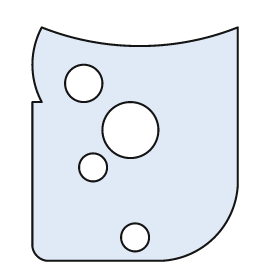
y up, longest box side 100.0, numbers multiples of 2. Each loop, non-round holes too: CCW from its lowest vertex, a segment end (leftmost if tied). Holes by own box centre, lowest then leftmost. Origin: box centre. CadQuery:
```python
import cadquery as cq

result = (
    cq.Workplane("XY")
    .moveTo(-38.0, -50.0)
    .lineTo(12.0, -50.0)
    .threePointArc((34.0, -40.0), (44.0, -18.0))
    .lineTo(44.0, 50.0)
    .threePointArc((2.0, 42.0), (-40.0, 50.0))
    .threePointArc((-44.0, 34.0), (-40.0, 18.0))
    .lineTo(-44.0, 18.0)
    .lineTo(-44.0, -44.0)
    .threePointArc((-42.0, -48.0), (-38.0, -50.0))
    .close()
    .moveTo(0.0, -40.0)
    .circle(6.0)
    .moveTo(-18.0, -10.0)
    .circle(6.0)
    .moveTo(-2.0, 6.0)
    .circle(12.0)
    .moveTo(-22.0, 26.0)
    .circle(8.0)
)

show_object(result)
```